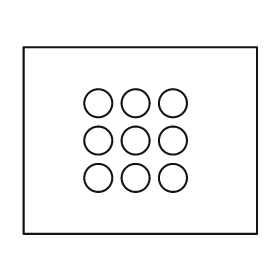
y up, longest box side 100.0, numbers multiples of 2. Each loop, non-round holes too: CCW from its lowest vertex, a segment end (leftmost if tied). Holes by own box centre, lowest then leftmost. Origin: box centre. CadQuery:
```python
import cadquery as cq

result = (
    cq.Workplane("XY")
    .moveTo(-50.0, -40.0)
    .lineTo(50.0, -40.0)
    .lineTo(50.0, 40.0)
    .lineTo(-50.0, 40.0)
    .close()
    .moveTo(-18.0, -16.0)
    .circle(6.0)
    .moveTo(-2.0, -16.0)
    .circle(6.0)
    .moveTo(14.0, -16.0)
    .circle(6.0)
    .moveTo(-18.0, 0.0)
    .circle(6.0)
    .moveTo(-2.0, 0.0)
    .circle(6.0)
    .moveTo(14.0, 0.0)
    .circle(6.0)
    .moveTo(-18.0, 16.0)
    .circle(6.0)
    .moveTo(-2.0, 16.0)
    .circle(6.0)
    .moveTo(14.0, 16.0)
    .circle(6.0)
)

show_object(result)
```